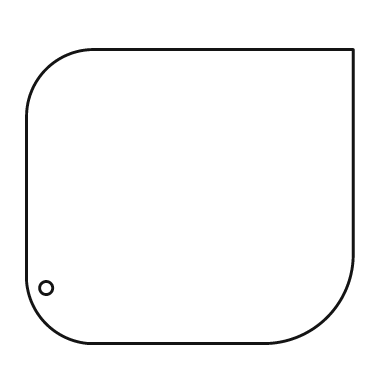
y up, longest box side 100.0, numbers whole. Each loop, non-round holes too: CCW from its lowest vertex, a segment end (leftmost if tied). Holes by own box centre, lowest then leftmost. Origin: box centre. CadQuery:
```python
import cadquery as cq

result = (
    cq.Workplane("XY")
    .moveTo(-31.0, -45.0)
    .lineTo(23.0, -45.0)
    .threePointArc((42.0, -37.0), (50.0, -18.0))
    .lineTo(50.0, 45.0)
    .lineTo(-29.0, 45.0)
    .threePointArc((-44.0, 39.0), (-50.0, 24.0))
    .lineTo(-50.0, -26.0)
    .threePointArc((-44.0, -39.0), (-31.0, -45.0))
    .close()
    .moveTo(-44.0, -28.0)
    .circle(2.0)
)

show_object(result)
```